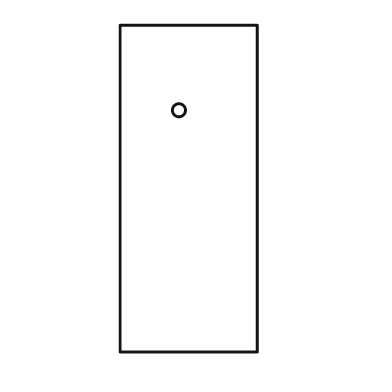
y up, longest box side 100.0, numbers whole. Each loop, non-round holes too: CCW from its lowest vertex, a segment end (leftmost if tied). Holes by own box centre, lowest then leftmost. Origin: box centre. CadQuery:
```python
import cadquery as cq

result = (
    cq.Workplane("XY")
    .moveTo(-21.0, -50.0)
    .lineTo(21.0, -50.0)
    .lineTo(21.0, 50.0)
    .lineTo(-21.0, 50.0)
    .close()
    .moveTo(-3.0, 24.0)
    .circle(2.0)
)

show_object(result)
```